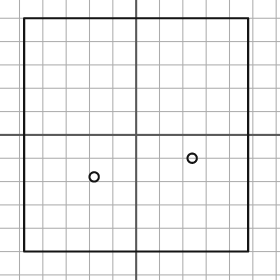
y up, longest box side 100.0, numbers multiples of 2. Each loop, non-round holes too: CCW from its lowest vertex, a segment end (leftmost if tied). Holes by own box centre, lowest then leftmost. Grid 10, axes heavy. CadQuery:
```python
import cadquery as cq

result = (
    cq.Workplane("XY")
    .moveTo(-48.0, -50.0)
    .lineTo(48.0, -50.0)
    .lineTo(48.0, 50.0)
    .lineTo(-48.0, 50.0)
    .close()
    .moveTo(-18.0, -18.0)
    .circle(2.0)
    .moveTo(24.0, -10.0)
    .circle(2.0)
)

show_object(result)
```